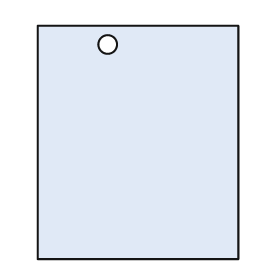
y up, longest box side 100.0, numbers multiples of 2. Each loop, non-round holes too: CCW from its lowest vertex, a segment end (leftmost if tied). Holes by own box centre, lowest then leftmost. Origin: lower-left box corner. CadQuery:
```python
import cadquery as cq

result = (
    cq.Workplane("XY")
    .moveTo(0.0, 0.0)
    .lineTo(86.0, 0.0)
    .lineTo(86.0, 100.0)
    .lineTo(0.0, 100.0)
    .close()
    .moveTo(30.0, 92.0)
    .circle(4.0)
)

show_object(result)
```